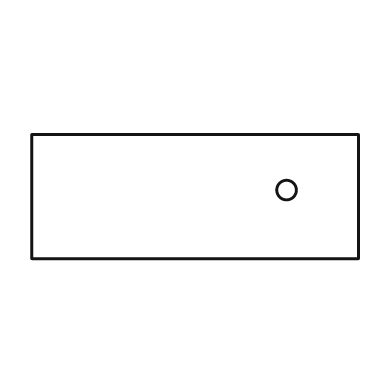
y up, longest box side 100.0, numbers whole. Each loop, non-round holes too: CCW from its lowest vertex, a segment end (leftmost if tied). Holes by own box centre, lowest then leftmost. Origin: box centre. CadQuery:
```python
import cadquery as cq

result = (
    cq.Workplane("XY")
    .moveTo(-50.0, -19.0)
    .lineTo(50.0, -19.0)
    .lineTo(50.0, 19.0)
    .lineTo(-50.0, 19.0)
    .close()
    .moveTo(28.0, 2.0)
    .circle(3.0)
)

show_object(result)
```